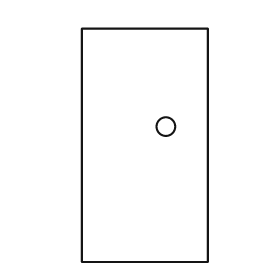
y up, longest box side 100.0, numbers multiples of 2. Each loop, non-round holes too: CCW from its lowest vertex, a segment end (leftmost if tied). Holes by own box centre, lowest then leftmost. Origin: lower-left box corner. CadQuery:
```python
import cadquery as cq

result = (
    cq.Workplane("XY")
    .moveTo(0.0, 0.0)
    .lineTo(54.0, 0.0)
    .lineTo(54.0, 100.0)
    .lineTo(0.0, 100.0)
    .close()
    .moveTo(36.0, 58.0)
    .circle(4.0)
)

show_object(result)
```